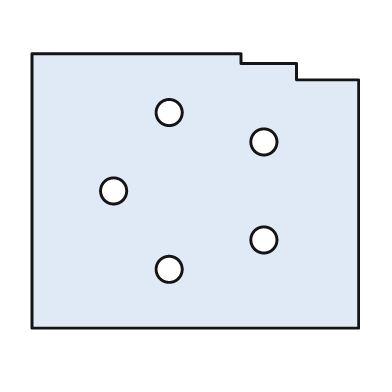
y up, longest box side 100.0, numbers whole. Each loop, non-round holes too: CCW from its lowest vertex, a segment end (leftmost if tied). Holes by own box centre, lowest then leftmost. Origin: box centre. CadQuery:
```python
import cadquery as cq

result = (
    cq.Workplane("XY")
    .moveTo(-50.0, -42.0)
    .lineTo(50.0, -42.0)
    .lineTo(50.0, 34.0)
    .lineTo(31.0, 34.0)
    .lineTo(31.0, 39.0)
    .lineTo(14.0, 39.0)
    .lineTo(14.0, 42.0)
    .lineTo(-50.0, 42.0)
    .close()
    .moveTo(-8.0, -24.0)
    .circle(4.0)
    .moveTo(21.0, -15.0)
    .circle(4.0)
    .moveTo(-25.0, 0.0)
    .circle(4.0)
    .moveTo(21.0, 15.0)
    .circle(4.0)
    .moveTo(-8.0, 24.0)
    .circle(4.0)
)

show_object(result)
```